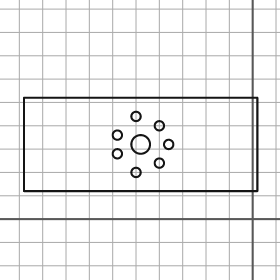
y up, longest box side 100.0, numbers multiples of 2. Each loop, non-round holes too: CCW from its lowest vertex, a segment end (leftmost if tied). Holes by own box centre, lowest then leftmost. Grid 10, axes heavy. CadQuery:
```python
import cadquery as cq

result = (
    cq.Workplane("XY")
    .moveTo(-98.0, 12.0)
    .lineTo(2.0, 12.0)
    .lineTo(2.0, 52.0)
    .lineTo(-98.0, 52.0)
    .close()
    .moveTo(-50.0, 20.0)
    .circle(2.0)
    .moveTo(-40.0, 24.0)
    .circle(2.0)
    .moveTo(-58.0, 28.0)
    .circle(2.0)
    .moveTo(-48.0, 32.0)
    .circle(4.0)
    .moveTo(-36.0, 32.0)
    .circle(2.0)
    .moveTo(-58.0, 36.0)
    .circle(2.0)
    .moveTo(-40.0, 40.0)
    .circle(2.0)
    .moveTo(-50.0, 44.0)
    .circle(2.0)
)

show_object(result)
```